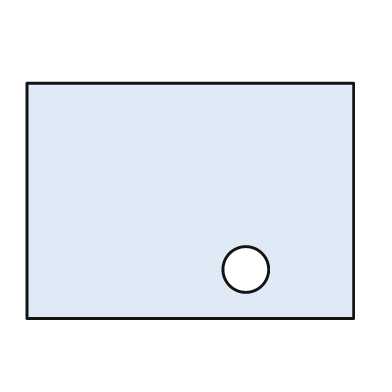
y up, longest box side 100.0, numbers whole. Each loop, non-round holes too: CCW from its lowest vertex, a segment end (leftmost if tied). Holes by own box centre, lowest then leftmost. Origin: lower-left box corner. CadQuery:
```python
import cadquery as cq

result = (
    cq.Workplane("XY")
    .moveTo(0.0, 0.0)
    .lineTo(100.0, 0.0)
    .lineTo(100.0, 72.0)
    .lineTo(0.0, 72.0)
    .close()
    .moveTo(67.0, 15.0)
    .circle(7.0)
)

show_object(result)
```